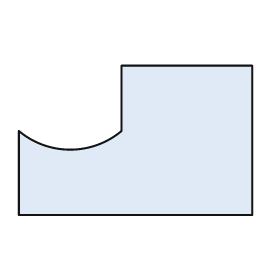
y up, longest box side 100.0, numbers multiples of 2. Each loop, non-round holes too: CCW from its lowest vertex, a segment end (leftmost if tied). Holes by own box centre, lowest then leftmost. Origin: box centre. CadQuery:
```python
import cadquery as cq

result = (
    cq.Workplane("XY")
    .moveTo(-50.0, -32.0)
    .lineTo(50.0, -32.0)
    .lineTo(50.0, 32.0)
    .lineTo(-6.0, 32.0)
    .lineTo(-6.0, 4.0)
    .threePointArc((-28.0, -4.0), (-50.0, 4.0))
    .close()
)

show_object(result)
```